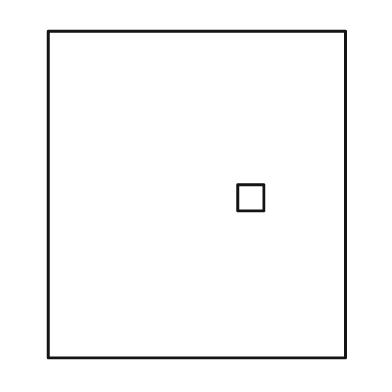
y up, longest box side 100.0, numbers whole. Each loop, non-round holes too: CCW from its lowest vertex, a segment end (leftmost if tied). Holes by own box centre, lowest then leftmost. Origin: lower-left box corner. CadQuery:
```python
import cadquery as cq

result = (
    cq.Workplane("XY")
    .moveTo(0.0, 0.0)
    .lineTo(91.0, 0.0)
    .lineTo(91.0, 100.0)
    .lineTo(0.0, 100.0)
    .close()
    .moveTo(58.0, 45.0)
    .lineTo(66.0, 45.0)
    .lineTo(66.0, 53.0)
    .lineTo(58.0, 53.0)
    .close()
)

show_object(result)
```